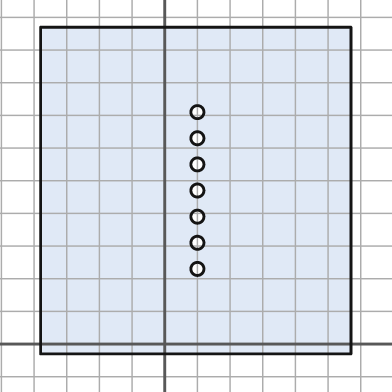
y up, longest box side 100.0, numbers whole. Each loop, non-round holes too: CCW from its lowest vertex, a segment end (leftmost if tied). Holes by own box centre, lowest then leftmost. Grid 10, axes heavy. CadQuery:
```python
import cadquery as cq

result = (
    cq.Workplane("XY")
    .moveTo(-38.0, -3.0)
    .lineTo(57.0, -3.0)
    .lineTo(57.0, 97.0)
    .lineTo(-38.0, 97.0)
    .close()
    .moveTo(10.0, 23.0)
    .circle(2.0)
    .moveTo(10.0, 31.0)
    .circle(2.0)
    .moveTo(10.0, 39.0)
    .circle(2.0)
    .moveTo(10.0, 47.0)
    .circle(2.0)
    .moveTo(10.0, 55.0)
    .circle(2.0)
    .moveTo(10.0, 63.0)
    .circle(2.0)
    .moveTo(10.0, 71.0)
    .circle(2.0)
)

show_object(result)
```